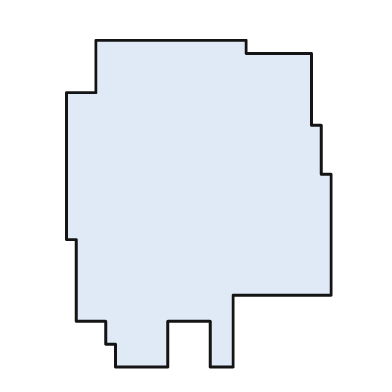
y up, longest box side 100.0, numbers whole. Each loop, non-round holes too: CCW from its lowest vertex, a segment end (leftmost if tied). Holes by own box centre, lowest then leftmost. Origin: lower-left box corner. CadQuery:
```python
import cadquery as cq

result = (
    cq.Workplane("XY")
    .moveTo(15.0, 0.0)
    .lineTo(31.0, 0.0)
    .lineTo(31.0, 14.0)
    .lineTo(44.0, 14.0)
    .lineTo(44.0, 0.0)
    .lineTo(51.0, 0.0)
    .lineTo(51.0, 22.0)
    .lineTo(81.0, 22.0)
    .lineTo(81.0, 59.0)
    .lineTo(78.0, 59.0)
    .lineTo(78.0, 74.0)
    .lineTo(75.0, 74.0)
    .lineTo(75.0, 96.0)
    .lineTo(55.0, 96.0)
    .lineTo(55.0, 100.0)
    .lineTo(9.0, 100.0)
    .lineTo(9.0, 84.0)
    .lineTo(0.0, 84.0)
    .lineTo(0.0, 39.0)
    .lineTo(3.0, 39.0)
    .lineTo(3.0, 14.0)
    .lineTo(12.0, 14.0)
    .lineTo(12.0, 7.0)
    .lineTo(15.0, 7.0)
    .close()
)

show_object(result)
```